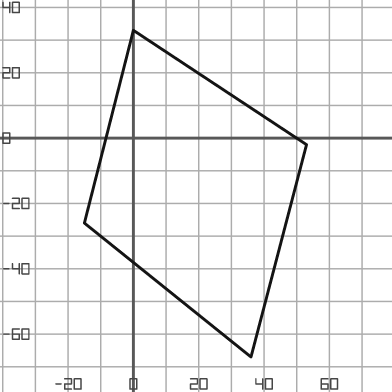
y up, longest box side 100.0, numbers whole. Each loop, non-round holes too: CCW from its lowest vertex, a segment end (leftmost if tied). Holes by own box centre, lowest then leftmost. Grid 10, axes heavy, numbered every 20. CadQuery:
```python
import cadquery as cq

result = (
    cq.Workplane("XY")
    .moveTo(36.0, -67.0)
    .lineTo(53.0, -2.0)
    .lineTo(0.0, 33.0)
    .lineTo(-15.0, -26.0)
    .close()
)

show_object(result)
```